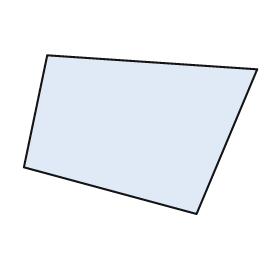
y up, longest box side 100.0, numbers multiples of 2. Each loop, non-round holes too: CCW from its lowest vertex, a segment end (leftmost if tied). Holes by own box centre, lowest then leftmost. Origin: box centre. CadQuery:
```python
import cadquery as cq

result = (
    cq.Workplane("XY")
    .moveTo(24.0, -34.0)
    .lineTo(50.0, 28.0)
    .lineTo(-40.0, 34.0)
    .lineTo(-50.0, -14.0)
    .close()
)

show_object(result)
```